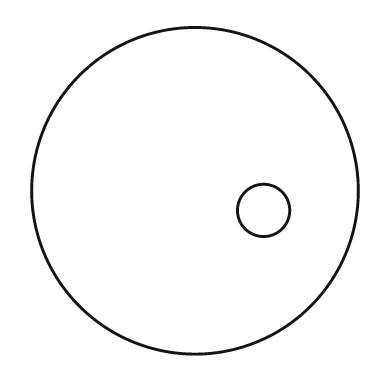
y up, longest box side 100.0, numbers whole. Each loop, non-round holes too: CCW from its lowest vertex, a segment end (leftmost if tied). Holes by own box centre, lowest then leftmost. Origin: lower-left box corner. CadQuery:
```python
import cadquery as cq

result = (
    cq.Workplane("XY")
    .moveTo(50.0, 50.0)
    .circle(50.0)
    .moveTo(71.0, 44.0)
    .circle(8.0)
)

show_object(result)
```